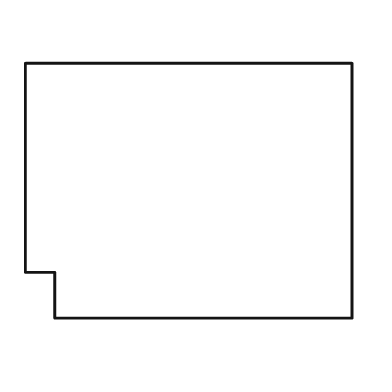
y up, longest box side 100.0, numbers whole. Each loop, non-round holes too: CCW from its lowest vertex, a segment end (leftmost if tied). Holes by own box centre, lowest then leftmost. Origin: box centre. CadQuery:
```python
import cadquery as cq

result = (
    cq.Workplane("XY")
    .moveTo(-41.0, -39.0)
    .lineTo(50.0, -39.0)
    .lineTo(50.0, 39.0)
    .lineTo(-50.0, 39.0)
    .lineTo(-50.0, -25.0)
    .lineTo(-41.0, -25.0)
    .close()
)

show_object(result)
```